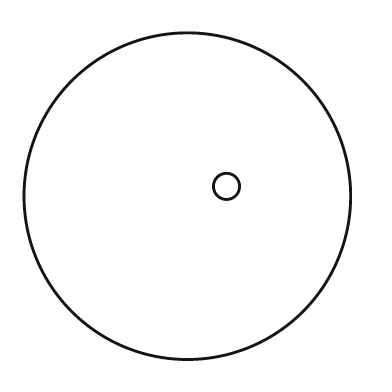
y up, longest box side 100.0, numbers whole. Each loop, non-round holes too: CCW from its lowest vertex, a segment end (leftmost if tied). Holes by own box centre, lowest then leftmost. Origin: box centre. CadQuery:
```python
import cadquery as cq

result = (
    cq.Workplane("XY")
    .moveTo(0.0, 0.0)
    .circle(50.0)
    .moveTo(12.0, 3.0)
    .circle(4.0)
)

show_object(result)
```